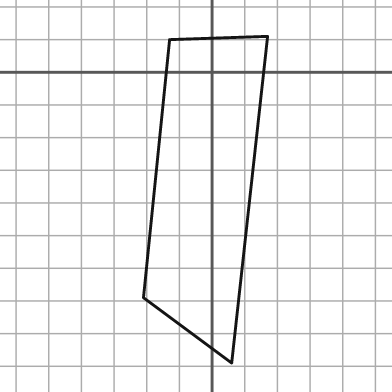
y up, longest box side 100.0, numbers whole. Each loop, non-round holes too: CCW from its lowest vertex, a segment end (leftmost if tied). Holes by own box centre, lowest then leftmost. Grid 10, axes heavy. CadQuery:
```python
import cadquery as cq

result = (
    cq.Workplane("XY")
    .moveTo(6.0, -89.0)
    .lineTo(17.0, 11.0)
    .lineTo(-13.0, 10.0)
    .lineTo(-21.0, -69.0)
    .close()
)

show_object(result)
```